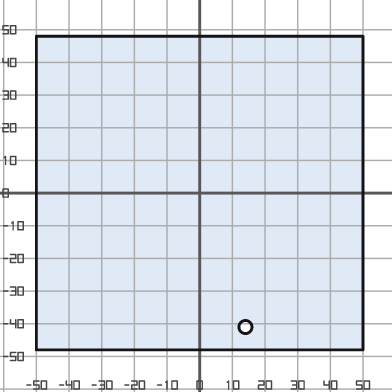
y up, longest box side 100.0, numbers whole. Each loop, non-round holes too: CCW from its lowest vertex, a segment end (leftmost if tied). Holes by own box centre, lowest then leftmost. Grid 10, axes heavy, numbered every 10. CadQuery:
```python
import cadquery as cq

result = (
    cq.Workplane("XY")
    .moveTo(-50.0, -48.0)
    .lineTo(50.0, -48.0)
    .lineTo(50.0, 48.0)
    .lineTo(-50.0, 48.0)
    .close()
    .moveTo(14.0, -41.0)
    .circle(2.0)
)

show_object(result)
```